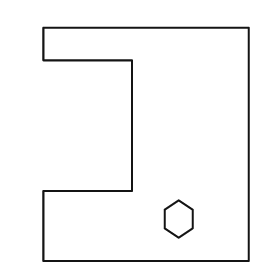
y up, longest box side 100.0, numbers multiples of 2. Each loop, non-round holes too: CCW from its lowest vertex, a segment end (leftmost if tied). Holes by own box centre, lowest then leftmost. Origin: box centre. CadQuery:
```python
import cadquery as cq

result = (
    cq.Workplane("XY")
    .moveTo(-44.0, -50.0)
    .lineTo(44.0, -50.0)
    .lineTo(44.0, 50.0)
    .lineTo(-44.0, 50.0)
    .lineTo(-44.0, 36.0)
    .lineTo(-6.0, 36.0)
    .lineTo(-6.0, -20.0)
    .lineTo(-44.0, -20.0)
    .close()
    .moveTo(14.0, -40.0)
    .lineTo(20.0, -36.0)
    .lineTo(20.0, -28.0)
    .lineTo(14.0, -24.0)
    .lineTo(8.0, -28.0)
    .lineTo(8.0, -36.0)
    .close()
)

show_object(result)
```